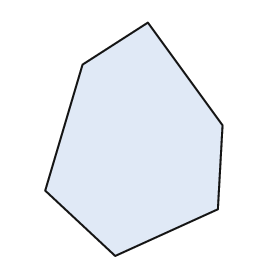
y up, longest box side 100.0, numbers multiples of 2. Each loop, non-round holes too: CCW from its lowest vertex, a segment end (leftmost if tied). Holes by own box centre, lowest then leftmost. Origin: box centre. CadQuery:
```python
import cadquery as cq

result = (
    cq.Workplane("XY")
    .moveTo(-8.0, -50.0)
    .lineTo(36.0, -30.0)
    .lineTo(38.0, 6.0)
    .lineTo(6.0, 50.0)
    .lineTo(-22.0, 32.0)
    .lineTo(-38.0, -22.0)
    .close()
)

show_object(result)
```